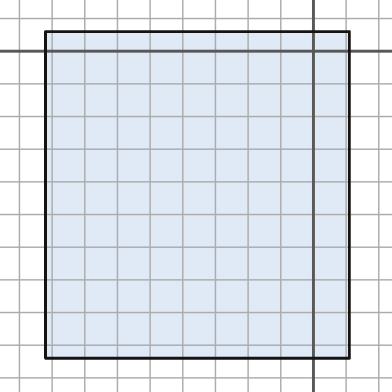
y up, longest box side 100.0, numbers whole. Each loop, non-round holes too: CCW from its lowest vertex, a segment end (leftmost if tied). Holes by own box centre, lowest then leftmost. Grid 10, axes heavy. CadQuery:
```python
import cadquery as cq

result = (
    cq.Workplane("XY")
    .moveTo(-82.0, -94.0)
    .lineTo(11.0, -94.0)
    .lineTo(11.0, 6.0)
    .lineTo(-82.0, 6.0)
    .close()
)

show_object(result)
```